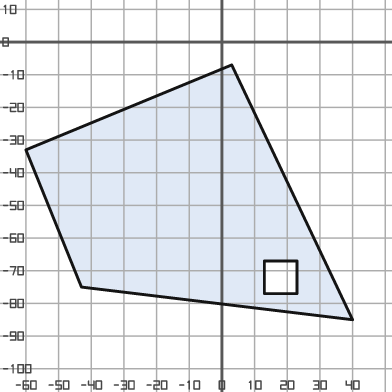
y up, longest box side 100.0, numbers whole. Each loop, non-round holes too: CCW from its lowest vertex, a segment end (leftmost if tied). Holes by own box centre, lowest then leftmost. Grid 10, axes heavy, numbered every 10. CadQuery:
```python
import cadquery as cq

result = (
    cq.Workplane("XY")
    .moveTo(40.0, -85.0)
    .lineTo(3.0, -7.0)
    .lineTo(-60.0, -33.0)
    .lineTo(-43.0, -75.0)
    .close()
    .moveTo(13.0, -77.0)
    .lineTo(23.0, -77.0)
    .lineTo(23.0, -67.0)
    .lineTo(13.0, -67.0)
    .close()
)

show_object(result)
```